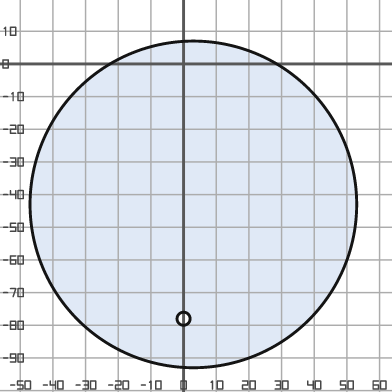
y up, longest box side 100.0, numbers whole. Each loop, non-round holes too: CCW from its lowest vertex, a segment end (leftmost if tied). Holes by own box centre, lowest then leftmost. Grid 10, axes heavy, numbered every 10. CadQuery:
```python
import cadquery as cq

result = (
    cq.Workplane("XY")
    .moveTo(3.0, -43.0)
    .circle(50.0)
    .moveTo(0.0, -78.0)
    .circle(2.0)
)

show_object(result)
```